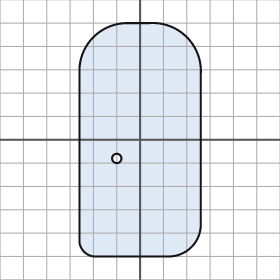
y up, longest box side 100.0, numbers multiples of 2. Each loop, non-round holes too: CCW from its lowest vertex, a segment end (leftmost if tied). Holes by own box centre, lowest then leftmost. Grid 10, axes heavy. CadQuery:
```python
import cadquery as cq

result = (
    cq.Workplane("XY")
    .moveTo(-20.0, -50.0)
    .lineTo(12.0, -50.0)
    .threePointArc((22.0, -46.0), (26.0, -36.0))
    .lineTo(26.0, 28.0)
    .threePointArc((20.0, 44.0), (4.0, 50.0))
    .lineTo(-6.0, 50.0)
    .threePointArc((-20.0, 44.0), (-26.0, 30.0))
    .lineTo(-26.0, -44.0)
    .threePointArc((-24.0, -48.0), (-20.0, -50.0))
    .close()
    .moveTo(-10.0, -8.0)
    .circle(2.0)
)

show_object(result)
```